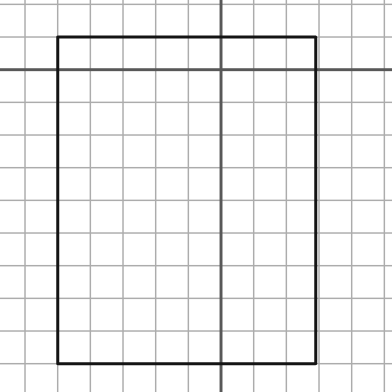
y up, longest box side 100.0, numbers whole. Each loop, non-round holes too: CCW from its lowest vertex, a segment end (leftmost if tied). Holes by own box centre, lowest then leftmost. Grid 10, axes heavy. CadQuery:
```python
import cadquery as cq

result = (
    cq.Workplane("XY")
    .moveTo(-50.0, -90.0)
    .lineTo(29.0, -90.0)
    .lineTo(29.0, 10.0)
    .lineTo(-50.0, 10.0)
    .close()
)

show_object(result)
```